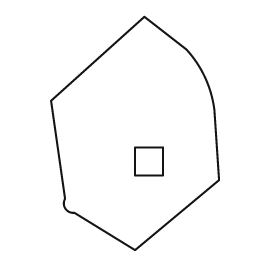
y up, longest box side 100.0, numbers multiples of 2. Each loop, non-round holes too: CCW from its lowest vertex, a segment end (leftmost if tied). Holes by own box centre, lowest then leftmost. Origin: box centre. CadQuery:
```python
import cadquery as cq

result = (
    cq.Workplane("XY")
    .moveTo(0.0, -50.0)
    .lineTo(36.0, -20.0)
    .lineTo(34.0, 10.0)
    .threePointArc((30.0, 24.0), (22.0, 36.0))
    .lineTo(4.0, 50.0)
    .lineTo(-36.0, 14.0)
    .lineTo(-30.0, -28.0)
    .threePointArc((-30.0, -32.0), (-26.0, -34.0))
    .close()
    .moveTo(0.0, -18.0)
    .lineTo(12.0, -18.0)
    .lineTo(12.0, -6.0)
    .lineTo(0.0, -6.0)
    .close()
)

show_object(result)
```